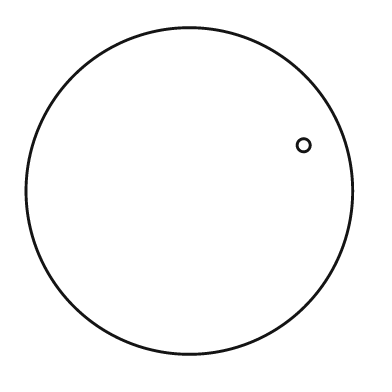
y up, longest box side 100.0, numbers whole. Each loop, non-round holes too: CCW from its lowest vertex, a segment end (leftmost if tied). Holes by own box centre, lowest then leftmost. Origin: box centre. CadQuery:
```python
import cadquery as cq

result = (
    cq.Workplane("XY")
    .moveTo(0.0, 0.0)
    .circle(50.0)
    .moveTo(35.0, 14.0)
    .circle(2.0)
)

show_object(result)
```